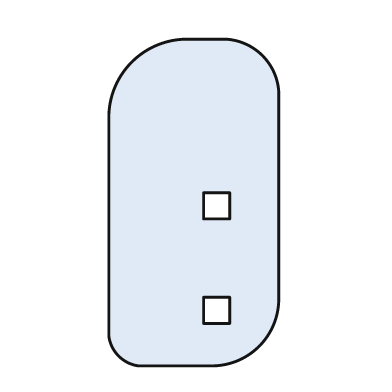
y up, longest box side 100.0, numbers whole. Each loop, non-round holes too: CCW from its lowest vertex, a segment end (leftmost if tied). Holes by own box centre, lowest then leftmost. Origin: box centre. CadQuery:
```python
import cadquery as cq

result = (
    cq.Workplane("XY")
    .moveTo(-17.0, -50.0)
    .lineTo(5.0, -50.0)
    .threePointArc((20.0, -44.0), (26.0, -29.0))
    .lineTo(26.0, 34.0)
    .threePointArc((21.0, 45.0), (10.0, 50.0))
    .lineTo(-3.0, 50.0)
    .threePointArc((-19.0, 43.0), (-26.0, 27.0))
    .lineTo(-26.0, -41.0)
    .threePointArc((-23.0, -47.0), (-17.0, -50.0))
    .close()
    .moveTo(3.0, -37.0)
    .lineTo(11.0, -37.0)
    .lineTo(11.0, -29.0)
    .lineTo(3.0, -29.0)
    .close()
    .moveTo(3.0, -5.0)
    .lineTo(11.0, -5.0)
    .lineTo(11.0, 3.0)
    .lineTo(3.0, 3.0)
    .close()
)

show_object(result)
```